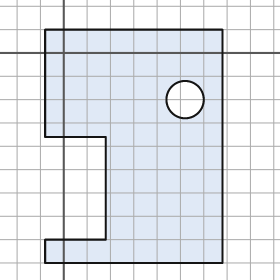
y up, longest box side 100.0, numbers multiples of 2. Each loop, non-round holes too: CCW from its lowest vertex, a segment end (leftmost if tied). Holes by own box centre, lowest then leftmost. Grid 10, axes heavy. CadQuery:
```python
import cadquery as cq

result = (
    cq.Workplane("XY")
    .moveTo(-8.0, -90.0)
    .lineTo(68.0, -90.0)
    .lineTo(68.0, 10.0)
    .lineTo(-8.0, 10.0)
    .lineTo(-8.0, -36.0)
    .lineTo(18.0, -36.0)
    .lineTo(18.0, -80.0)
    .lineTo(-8.0, -80.0)
    .close()
    .moveTo(52.0, -20.0)
    .circle(8.0)
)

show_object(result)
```